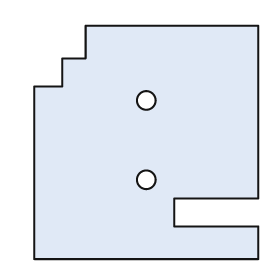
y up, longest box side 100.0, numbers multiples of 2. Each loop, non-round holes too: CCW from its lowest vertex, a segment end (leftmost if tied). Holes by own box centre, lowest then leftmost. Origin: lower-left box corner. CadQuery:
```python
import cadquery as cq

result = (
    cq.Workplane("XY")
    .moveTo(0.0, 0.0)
    .lineTo(96.0, 0.0)
    .lineTo(96.0, 14.0)
    .lineTo(60.0, 14.0)
    .lineTo(60.0, 26.0)
    .lineTo(96.0, 26.0)
    .lineTo(96.0, 100.0)
    .lineTo(22.0, 100.0)
    .lineTo(22.0, 86.0)
    .lineTo(12.0, 86.0)
    .lineTo(12.0, 74.0)
    .lineTo(0.0, 74.0)
    .close()
    .moveTo(48.0, 34.0)
    .circle(4.0)
    .moveTo(48.0, 68.0)
    .circle(4.0)
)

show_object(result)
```